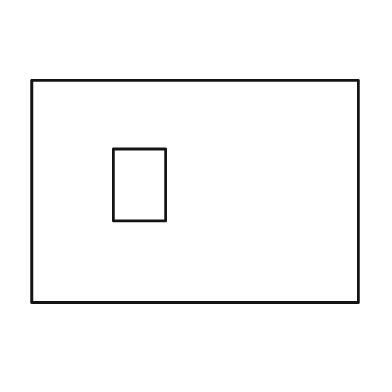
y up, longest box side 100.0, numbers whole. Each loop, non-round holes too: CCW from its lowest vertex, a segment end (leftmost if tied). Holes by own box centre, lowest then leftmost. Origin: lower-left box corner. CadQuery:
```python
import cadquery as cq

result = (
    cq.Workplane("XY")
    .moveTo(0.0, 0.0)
    .lineTo(100.0, 0.0)
    .lineTo(100.0, 68.0)
    .lineTo(0.0, 68.0)
    .close()
    .moveTo(25.0, 25.0)
    .lineTo(41.0, 25.0)
    .lineTo(41.0, 47.0)
    .lineTo(25.0, 47.0)
    .close()
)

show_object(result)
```